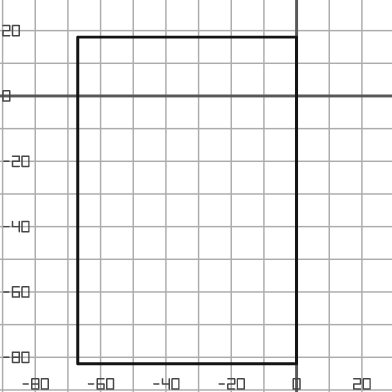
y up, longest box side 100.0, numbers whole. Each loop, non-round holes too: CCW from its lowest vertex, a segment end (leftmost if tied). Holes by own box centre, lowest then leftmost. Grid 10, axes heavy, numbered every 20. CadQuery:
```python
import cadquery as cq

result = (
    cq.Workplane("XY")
    .moveTo(-67.0, -82.0)
    .lineTo(0.0, -82.0)
    .lineTo(0.0, 18.0)
    .lineTo(-67.0, 18.0)
    .close()
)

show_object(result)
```